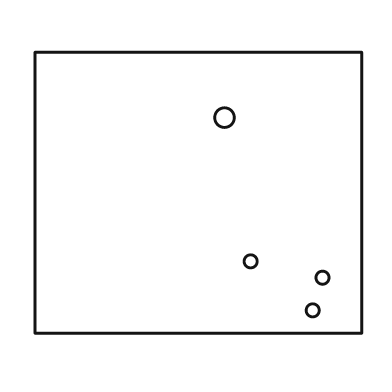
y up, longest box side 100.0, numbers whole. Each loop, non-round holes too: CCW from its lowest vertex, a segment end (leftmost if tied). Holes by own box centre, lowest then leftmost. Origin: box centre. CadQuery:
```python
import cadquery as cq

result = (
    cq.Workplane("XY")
    .moveTo(-50.0, -43.0)
    .lineTo(50.0, -43.0)
    .lineTo(50.0, 43.0)
    .lineTo(-50.0, 43.0)
    .close()
    .moveTo(35.0, -36.0)
    .circle(2.0)
    .moveTo(38.0, -26.0)
    .circle(2.0)
    .moveTo(16.0, -21.0)
    .circle(2.0)
    .moveTo(8.0, 23.0)
    .circle(3.0)
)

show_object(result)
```